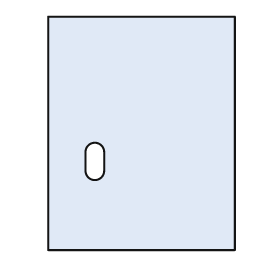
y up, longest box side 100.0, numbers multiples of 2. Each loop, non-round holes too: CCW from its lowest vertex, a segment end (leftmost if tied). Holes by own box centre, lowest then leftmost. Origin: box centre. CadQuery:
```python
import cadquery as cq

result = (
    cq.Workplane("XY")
    .moveTo(-40.0, -50.0)
    .lineTo(40.0, -50.0)
    .lineTo(40.0, 50.0)
    .lineTo(-40.0, 50.0)
    .close()
    .moveTo(-24.0, -16.0)
    .threePointArc((-20.0, -20.0), (-16.0, -16.0))
    .lineTo(-16.0, -8.0)
    .threePointArc((-20.0, -4.0), (-24.0, -8.0))
    .close()
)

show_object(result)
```